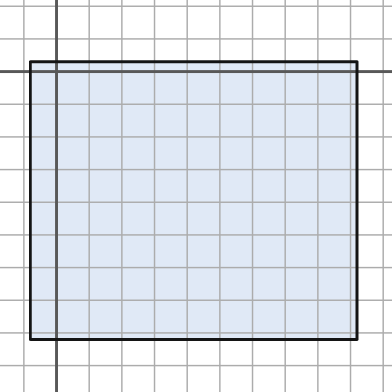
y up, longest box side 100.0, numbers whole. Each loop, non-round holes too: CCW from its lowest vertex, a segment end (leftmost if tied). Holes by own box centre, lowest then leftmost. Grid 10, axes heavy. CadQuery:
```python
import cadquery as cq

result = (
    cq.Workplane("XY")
    .moveTo(-8.0, -82.0)
    .lineTo(92.0, -82.0)
    .lineTo(92.0, 3.0)
    .lineTo(-8.0, 3.0)
    .close()
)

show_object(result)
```